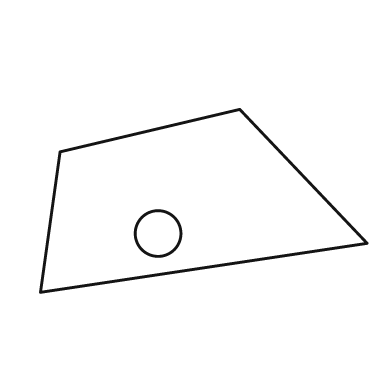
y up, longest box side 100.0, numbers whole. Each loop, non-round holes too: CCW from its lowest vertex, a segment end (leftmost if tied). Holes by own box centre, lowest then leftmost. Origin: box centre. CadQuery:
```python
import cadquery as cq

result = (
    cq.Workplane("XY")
    .moveTo(-50.0, -28.0)
    .lineTo(50.0, -13.0)
    .lineTo(11.0, 28.0)
    .lineTo(-44.0, 15.0)
    .close()
    .moveTo(-14.0, -10.0)
    .circle(7.0)
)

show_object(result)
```